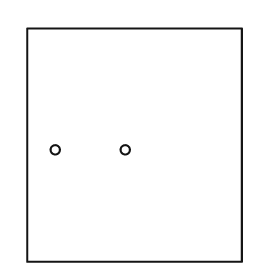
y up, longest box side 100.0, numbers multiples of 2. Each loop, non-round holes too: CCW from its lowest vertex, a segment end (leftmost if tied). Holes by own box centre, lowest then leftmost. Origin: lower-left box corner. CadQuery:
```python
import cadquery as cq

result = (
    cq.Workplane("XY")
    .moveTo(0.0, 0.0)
    .lineTo(92.0, 0.0)
    .lineTo(92.0, 100.0)
    .lineTo(0.0, 100.0)
    .close()
    .moveTo(12.0, 48.0)
    .circle(2.0)
    .moveTo(42.0, 48.0)
    .circle(2.0)
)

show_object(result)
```